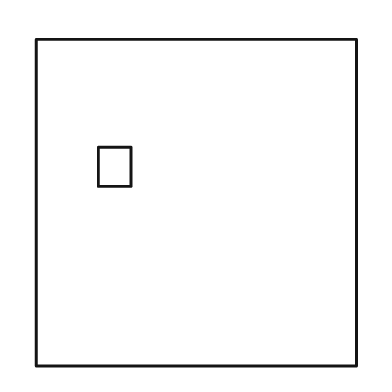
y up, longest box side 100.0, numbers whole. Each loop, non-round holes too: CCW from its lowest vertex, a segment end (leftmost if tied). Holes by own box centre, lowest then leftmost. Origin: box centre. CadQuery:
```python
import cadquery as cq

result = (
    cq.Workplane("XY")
    .moveTo(-49.0, -50.0)
    .lineTo(49.0, -50.0)
    .lineTo(49.0, 50.0)
    .lineTo(-49.0, 50.0)
    .close()
    .moveTo(-30.0, 5.0)
    .lineTo(-20.0, 5.0)
    .lineTo(-20.0, 17.0)
    .lineTo(-30.0, 17.0)
    .close()
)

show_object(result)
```